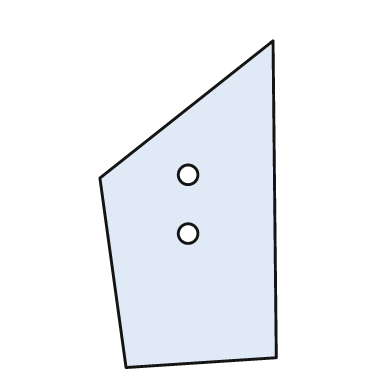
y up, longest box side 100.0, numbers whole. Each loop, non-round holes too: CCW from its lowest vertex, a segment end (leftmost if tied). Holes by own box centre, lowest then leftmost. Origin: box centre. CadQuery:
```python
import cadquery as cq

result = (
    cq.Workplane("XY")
    .moveTo(-19.0, -50.0)
    .lineTo(27.0, -47.0)
    .lineTo(26.0, 50.0)
    .lineTo(-27.0, 8.0)
    .close()
    .moveTo(0.0, -9.0)
    .circle(3.0)
    .moveTo(0.0, 9.0)
    .circle(3.0)
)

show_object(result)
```